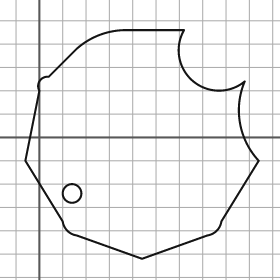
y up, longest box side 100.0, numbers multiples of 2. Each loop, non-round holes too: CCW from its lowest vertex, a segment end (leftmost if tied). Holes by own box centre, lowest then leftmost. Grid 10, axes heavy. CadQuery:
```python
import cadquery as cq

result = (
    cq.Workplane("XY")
    .moveTo(44.0, -52.0)
    .lineTo(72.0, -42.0)
    .threePointArc((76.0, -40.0), (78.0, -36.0))
    .lineTo(94.0, -10.0)
    .threePointArc((86.0, 6.0), (88.0, 24.0))
    .threePointArc((66.0, 24.0), (62.0, 46.0))
    .lineTo(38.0, 46.0)
    .threePointArc((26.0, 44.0), (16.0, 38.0))
    .lineTo(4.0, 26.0)
    .threePointArc((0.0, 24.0), (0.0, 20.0))
    .lineTo(-6.0, -10.0)
    .lineTo(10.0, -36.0)
    .threePointArc((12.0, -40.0), (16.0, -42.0))
    .close()
    .moveTo(14.0, -24.0)
    .circle(4.0)
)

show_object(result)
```